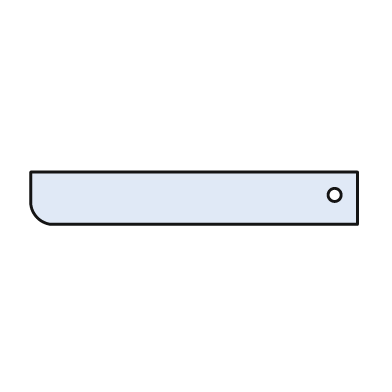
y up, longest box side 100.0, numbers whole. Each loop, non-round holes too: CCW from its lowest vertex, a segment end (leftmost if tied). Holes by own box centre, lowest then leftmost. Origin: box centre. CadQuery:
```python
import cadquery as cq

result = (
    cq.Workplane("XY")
    .moveTo(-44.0, -8.0)
    .lineTo(50.0, -8.0)
    .lineTo(50.0, 8.0)
    .lineTo(-50.0, 8.0)
    .lineTo(-50.0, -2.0)
    .threePointArc((-48.0, -6.0), (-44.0, -8.0))
    .close()
    .moveTo(43.0, 1.0)
    .circle(2.0)
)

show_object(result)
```